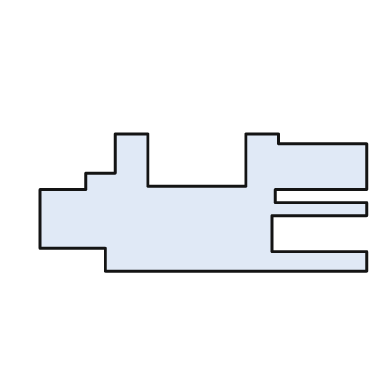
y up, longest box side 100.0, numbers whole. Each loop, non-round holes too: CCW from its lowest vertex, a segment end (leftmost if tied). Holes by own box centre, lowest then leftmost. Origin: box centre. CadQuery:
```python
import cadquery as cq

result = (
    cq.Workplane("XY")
    .moveTo(-30.0, -21.0)
    .lineTo(50.0, -21.0)
    .lineTo(50.0, -15.0)
    .lineTo(21.0, -15.0)
    .lineTo(21.0, -4.0)
    .lineTo(50.0, -4.0)
    .lineTo(50.0, 0.0)
    .lineTo(22.0, 0.0)
    .lineTo(22.0, 4.0)
    .lineTo(50.0, 4.0)
    .lineTo(50.0, 18.0)
    .lineTo(23.0, 18.0)
    .lineTo(23.0, 21.0)
    .lineTo(13.0, 21.0)
    .lineTo(13.0, 5.0)
    .lineTo(-17.0, 5.0)
    .lineTo(-17.0, 21.0)
    .lineTo(-27.0, 21.0)
    .lineTo(-27.0, 9.0)
    .lineTo(-36.0, 9.0)
    .lineTo(-36.0, 4.0)
    .lineTo(-50.0, 4.0)
    .lineTo(-50.0, -14.0)
    .lineTo(-30.0, -14.0)
    .close()
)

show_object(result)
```